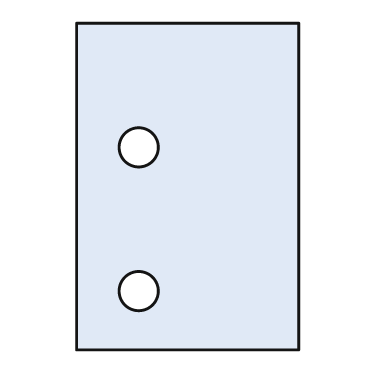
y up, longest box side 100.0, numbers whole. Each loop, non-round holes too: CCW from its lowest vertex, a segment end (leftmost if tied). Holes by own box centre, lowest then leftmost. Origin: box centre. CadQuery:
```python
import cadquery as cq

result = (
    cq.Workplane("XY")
    .moveTo(-34.0, -50.0)
    .lineTo(34.0, -50.0)
    .lineTo(34.0, 50.0)
    .lineTo(-34.0, 50.0)
    .close()
    .moveTo(-15.0, -32.0)
    .circle(6.0)
    .moveTo(-15.0, 12.0)
    .circle(6.0)
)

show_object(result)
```